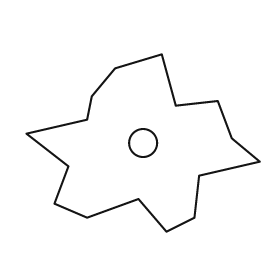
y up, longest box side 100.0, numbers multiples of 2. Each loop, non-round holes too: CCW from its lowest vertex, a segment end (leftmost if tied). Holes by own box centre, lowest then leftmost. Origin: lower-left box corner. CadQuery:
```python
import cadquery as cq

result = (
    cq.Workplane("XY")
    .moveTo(60.0, 0.0)
    .lineTo(72.0, 6.0)
    .lineTo(74.0, 24.0)
    .lineTo(100.0, 30.0)
    .lineTo(88.0, 40.0)
    .lineTo(82.0, 56.0)
    .lineTo(64.0, 54.0)
    .lineTo(58.0, 76.0)
    .lineTo(38.0, 70.0)
    .lineTo(28.0, 58.0)
    .lineTo(26.0, 48.0)
    .lineTo(0.0, 42.0)
    .lineTo(18.0, 28.0)
    .lineTo(12.0, 12.0)
    .lineTo(26.0, 6.0)
    .lineTo(48.0, 14.0)
    .close()
    .moveTo(50.0, 38.0)
    .circle(6.0)
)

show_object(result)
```